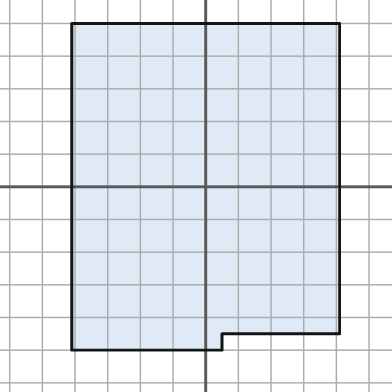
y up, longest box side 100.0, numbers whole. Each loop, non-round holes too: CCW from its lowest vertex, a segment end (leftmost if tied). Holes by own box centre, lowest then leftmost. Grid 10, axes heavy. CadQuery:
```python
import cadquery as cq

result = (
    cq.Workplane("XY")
    .moveTo(-41.0, -50.0)
    .lineTo(5.0, -50.0)
    .lineTo(5.0, -45.0)
    .lineTo(41.0, -45.0)
    .lineTo(41.0, 50.0)
    .lineTo(-41.0, 50.0)
    .close()
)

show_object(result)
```